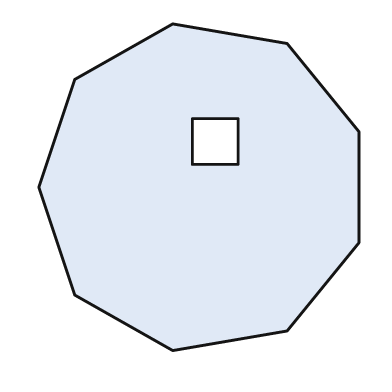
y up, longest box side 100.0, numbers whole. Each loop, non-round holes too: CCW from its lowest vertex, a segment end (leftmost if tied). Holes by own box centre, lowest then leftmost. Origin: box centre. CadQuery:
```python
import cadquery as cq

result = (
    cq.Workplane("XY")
    .moveTo(-8.0, -50.0)
    .lineTo(27.0, -44.0)
    .lineTo(49.0, -17.0)
    .lineTo(49.0, 17.0)
    .lineTo(27.0, 44.0)
    .lineTo(-8.0, 50.0)
    .lineTo(-38.0, 33.0)
    .lineTo(-49.0, 0.0)
    .lineTo(-38.0, -33.0)
    .close()
    .moveTo(-2.0, 7.0)
    .lineTo(12.0, 7.0)
    .lineTo(12.0, 21.0)
    .lineTo(-2.0, 21.0)
    .close()
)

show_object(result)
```